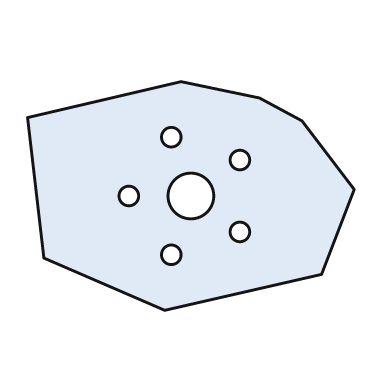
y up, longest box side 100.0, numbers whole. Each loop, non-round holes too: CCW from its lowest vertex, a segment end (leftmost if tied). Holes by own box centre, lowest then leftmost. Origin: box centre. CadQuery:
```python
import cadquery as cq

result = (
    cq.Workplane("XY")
    .moveTo(-8.0, -35.0)
    .lineTo(40.0, -24.0)
    .lineTo(50.0, 2.0)
    .lineTo(34.0, 23.0)
    .lineTo(21.0, 30.0)
    .lineTo(-3.0, 35.0)
    .lineTo(-50.0, 24.0)
    .lineTo(-45.0, -19.0)
    .close()
    .moveTo(-6.0, -18.0)
    .circle(3.0)
    .moveTo(15.0, -11.0)
    .circle(3.0)
    .moveTo(-19.0, 0.0)
    .circle(3.0)
    .moveTo(0.0, 0.0)
    .circle(7.0)
    .moveTo(15.0, 11.0)
    .circle(3.0)
    .moveTo(-6.0, 18.0)
    .circle(3.0)
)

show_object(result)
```